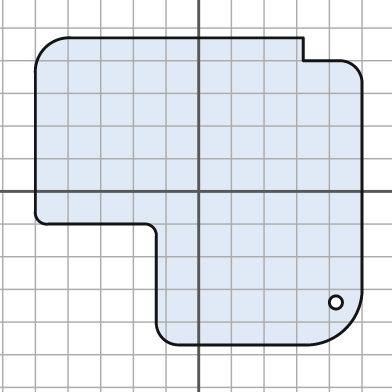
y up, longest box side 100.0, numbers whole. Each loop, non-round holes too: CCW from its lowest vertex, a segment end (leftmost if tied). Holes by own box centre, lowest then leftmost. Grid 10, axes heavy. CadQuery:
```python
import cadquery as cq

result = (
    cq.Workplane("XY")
    .moveTo(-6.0, -47.0)
    .lineTo(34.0, -47.0)
    .threePointArc((45.0, -42.0), (50.0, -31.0))
    .lineTo(50.0, 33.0)
    .threePointArc((48.0, 38.0), (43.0, 40.0))
    .lineTo(32.0, 40.0)
    .lineTo(32.0, 47.0)
    .lineTo(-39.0, 47.0)
    .threePointArc((-47.0, 44.0), (-50.0, 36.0))
    .lineTo(-50.0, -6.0)
    .threePointArc((-49.0, -9.0), (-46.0, -10.0))
    .lineTo(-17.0, -10.0)
    .threePointArc((-14.0, -11.0), (-13.0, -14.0))
    .lineTo(-13.0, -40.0)
    .threePointArc((-11.0, -45.0), (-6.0, -47.0))
    .close()
    .moveTo(42.0, -34.0)
    .circle(2.0)
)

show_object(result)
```